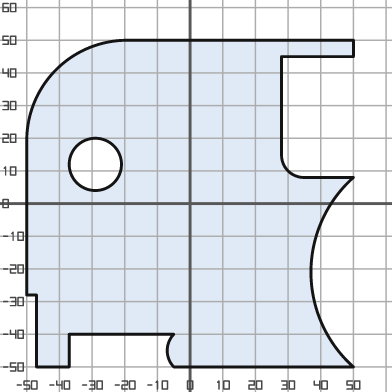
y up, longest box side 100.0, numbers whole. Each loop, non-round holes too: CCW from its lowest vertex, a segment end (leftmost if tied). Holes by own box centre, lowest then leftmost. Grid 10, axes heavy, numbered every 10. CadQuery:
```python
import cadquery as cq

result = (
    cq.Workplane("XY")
    .moveTo(-47.0, -50.0)
    .lineTo(-37.0, -50.0)
    .lineTo(-37.0, -40.0)
    .lineTo(-5.0, -40.0)
    .threePointArc((-7.0, -45.0), (-5.0, -50.0))
    .lineTo(50.0, -50.0)
    .threePointArc((37.0, -21.0), (50.0, 8.0))
    .lineTo(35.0, 8.0)
    .threePointArc((30.0, 10.0), (28.0, 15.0))
    .lineTo(28.0, 45.0)
    .lineTo(50.0, 45.0)
    .lineTo(50.0, 50.0)
    .lineTo(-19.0, 50.0)
    .threePointArc((-41.0, 41.0), (-50.0, 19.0))
    .lineTo(-50.0, -28.0)
    .lineTo(-47.0, -28.0)
    .close()
    .moveTo(-29.0, 12.0)
    .circle(8.0)
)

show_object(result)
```